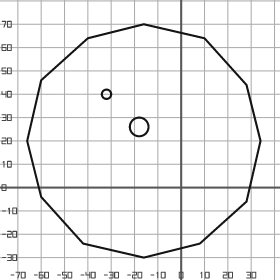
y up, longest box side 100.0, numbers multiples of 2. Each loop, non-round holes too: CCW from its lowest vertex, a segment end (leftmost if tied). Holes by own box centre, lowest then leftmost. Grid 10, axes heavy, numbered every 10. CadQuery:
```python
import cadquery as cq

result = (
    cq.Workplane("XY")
    .moveTo(-16.0, -30.0)
    .lineTo(8.0, -24.0)
    .lineTo(28.0, -6.0)
    .lineTo(34.0, 20.0)
    .lineTo(28.0, 44.0)
    .lineTo(10.0, 64.0)
    .lineTo(-16.0, 70.0)
    .lineTo(-40.0, 64.0)
    .lineTo(-60.0, 46.0)
    .lineTo(-66.0, 20.0)
    .lineTo(-60.0, -4.0)
    .lineTo(-42.0, -24.0)
    .close()
    .moveTo(-18.0, 26.0)
    .circle(4.0)
    .moveTo(-32.0, 40.0)
    .circle(2.0)
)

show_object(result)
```